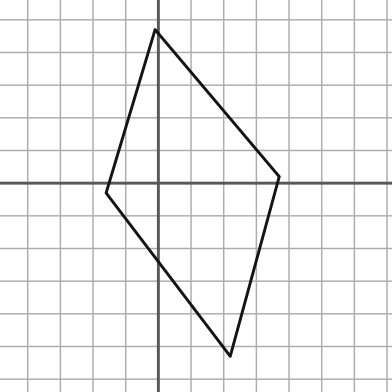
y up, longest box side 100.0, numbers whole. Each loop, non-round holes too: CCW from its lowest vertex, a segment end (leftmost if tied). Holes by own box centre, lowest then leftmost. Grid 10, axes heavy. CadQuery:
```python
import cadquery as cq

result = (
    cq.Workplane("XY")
    .moveTo(22.0, -53.0)
    .lineTo(37.0, 2.0)
    .lineTo(-1.0, 47.0)
    .lineTo(-16.0, -3.0)
    .close()
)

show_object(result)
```